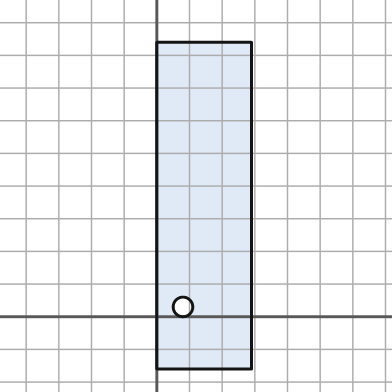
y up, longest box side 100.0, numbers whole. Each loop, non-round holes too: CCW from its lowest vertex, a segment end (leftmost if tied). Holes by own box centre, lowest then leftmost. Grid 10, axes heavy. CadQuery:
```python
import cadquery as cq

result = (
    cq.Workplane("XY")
    .moveTo(0.0, -16.0)
    .lineTo(29.0, -16.0)
    .lineTo(29.0, 84.0)
    .lineTo(0.0, 84.0)
    .close()
    .moveTo(8.0, 3.0)
    .circle(3.0)
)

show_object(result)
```